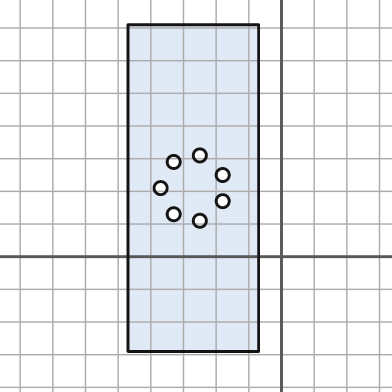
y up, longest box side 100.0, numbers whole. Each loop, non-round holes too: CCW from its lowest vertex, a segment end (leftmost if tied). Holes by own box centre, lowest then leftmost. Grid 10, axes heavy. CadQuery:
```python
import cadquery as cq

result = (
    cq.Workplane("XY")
    .moveTo(-47.0, -29.0)
    .lineTo(-7.0, -29.0)
    .lineTo(-7.0, 71.0)
    .lineTo(-47.0, 71.0)
    .close()
    .moveTo(-25.0, 11.0)
    .circle(2.0)
    .moveTo(-33.0, 13.0)
    .circle(2.0)
    .moveTo(-18.0, 17.0)
    .circle(2.0)
    .moveTo(-37.0, 21.0)
    .circle(2.0)
    .moveTo(-18.0, 25.0)
    .circle(2.0)
    .moveTo(-33.0, 29.0)
    .circle(2.0)
    .moveTo(-25.0, 31.0)
    .circle(2.0)
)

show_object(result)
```